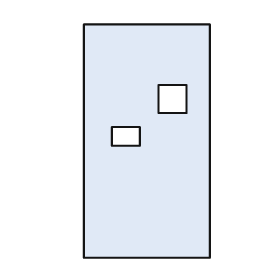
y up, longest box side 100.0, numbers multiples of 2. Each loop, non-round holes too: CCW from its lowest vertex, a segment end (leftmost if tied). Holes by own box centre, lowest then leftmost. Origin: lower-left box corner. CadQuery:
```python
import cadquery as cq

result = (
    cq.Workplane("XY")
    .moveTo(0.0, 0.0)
    .lineTo(54.0, 0.0)
    .lineTo(54.0, 100.0)
    .lineTo(0.0, 100.0)
    .close()
    .moveTo(12.0, 48.0)
    .lineTo(24.0, 48.0)
    .lineTo(24.0, 56.0)
    .lineTo(12.0, 56.0)
    .close()
    .moveTo(32.0, 62.0)
    .lineTo(44.0, 62.0)
    .lineTo(44.0, 74.0)
    .lineTo(32.0, 74.0)
    .close()
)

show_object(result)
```